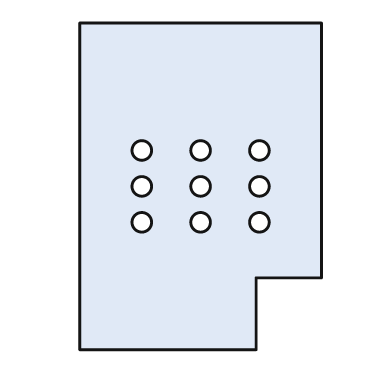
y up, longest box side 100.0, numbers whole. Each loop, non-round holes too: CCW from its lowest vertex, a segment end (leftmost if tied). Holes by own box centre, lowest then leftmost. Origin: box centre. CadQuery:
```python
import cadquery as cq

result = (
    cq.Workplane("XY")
    .moveTo(-37.0, -50.0)
    .lineTo(17.0, -50.0)
    .lineTo(17.0, -28.0)
    .lineTo(37.0, -28.0)
    .lineTo(37.0, 50.0)
    .lineTo(-37.0, 50.0)
    .close()
    .moveTo(-18.0, -11.0)
    .circle(3.0)
    .moveTo(0.0, -11.0)
    .circle(3.0)
    .moveTo(18.0, -11.0)
    .circle(3.0)
    .moveTo(-18.0, 0.0)
    .circle(3.0)
    .moveTo(0.0, 0.0)
    .circle(3.0)
    .moveTo(18.0, 0.0)
    .circle(3.0)
    .moveTo(-18.0, 11.0)
    .circle(3.0)
    .moveTo(0.0, 11.0)
    .circle(3.0)
    .moveTo(18.0, 11.0)
    .circle(3.0)
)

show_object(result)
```